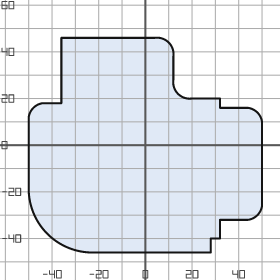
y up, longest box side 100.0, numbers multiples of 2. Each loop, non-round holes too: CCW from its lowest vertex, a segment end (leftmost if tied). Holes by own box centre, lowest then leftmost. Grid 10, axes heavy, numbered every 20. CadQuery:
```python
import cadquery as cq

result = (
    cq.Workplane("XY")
    .moveTo(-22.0, -46.0)
    .lineTo(28.0, -46.0)
    .lineTo(28.0, -40.0)
    .lineTo(32.0, -40.0)
    .lineTo(32.0, -32.0)
    .lineTo(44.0, -32.0)
    .threePointArc((48.0, -30.0), (50.0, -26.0))
    .lineTo(50.0, 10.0)
    .threePointArc((48.0, 14.0), (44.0, 16.0))
    .lineTo(32.0, 16.0)
    .lineTo(32.0, 20.0)
    .lineTo(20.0, 20.0)
    .threePointArc((14.0, 22.0), (12.0, 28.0))
    .lineTo(12.0, 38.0)
    .threePointArc((10.0, 44.0), (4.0, 46.0))
    .lineTo(-36.0, 46.0)
    .lineTo(-36.0, 18.0)
    .lineTo(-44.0, 18.0)
    .threePointArc((-48.0, 16.0), (-50.0, 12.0))
    .lineTo(-50.0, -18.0)
    .threePointArc((-42.0, -38.0), (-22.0, -46.0))
    .close()
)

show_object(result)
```